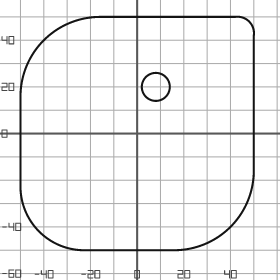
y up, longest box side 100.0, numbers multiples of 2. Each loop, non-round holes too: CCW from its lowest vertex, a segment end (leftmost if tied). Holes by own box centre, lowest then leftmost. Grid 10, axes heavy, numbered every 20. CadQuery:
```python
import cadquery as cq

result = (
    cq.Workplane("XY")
    .moveTo(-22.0, -50.0)
    .lineTo(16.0, -50.0)
    .threePointArc((40.0, -40.0), (50.0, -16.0))
    .lineTo(50.0, 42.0)
    .threePointArc((48.0, 48.0), (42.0, 50.0))
    .lineTo(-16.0, 50.0)
    .threePointArc((-40.0, 40.0), (-50.0, 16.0))
    .lineTo(-50.0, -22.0)
    .threePointArc((-42.0, -42.0), (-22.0, -50.0))
    .close()
    .moveTo(8.0, 20.0)
    .circle(6.0)
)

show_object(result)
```